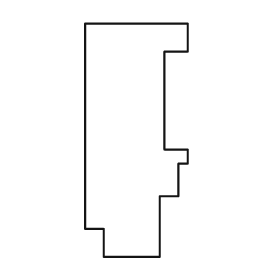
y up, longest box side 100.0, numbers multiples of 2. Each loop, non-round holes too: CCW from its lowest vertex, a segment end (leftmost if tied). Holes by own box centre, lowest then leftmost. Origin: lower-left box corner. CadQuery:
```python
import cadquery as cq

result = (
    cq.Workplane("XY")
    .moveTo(8.0, 0.0)
    .lineTo(32.0, 0.0)
    .lineTo(32.0, 26.0)
    .lineTo(40.0, 26.0)
    .lineTo(40.0, 40.0)
    .lineTo(44.0, 40.0)
    .lineTo(44.0, 46.0)
    .lineTo(34.0, 46.0)
    .lineTo(34.0, 88.0)
    .lineTo(44.0, 88.0)
    .lineTo(44.0, 100.0)
    .lineTo(0.0, 100.0)
    .lineTo(0.0, 12.0)
    .lineTo(8.0, 12.0)
    .close()
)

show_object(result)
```